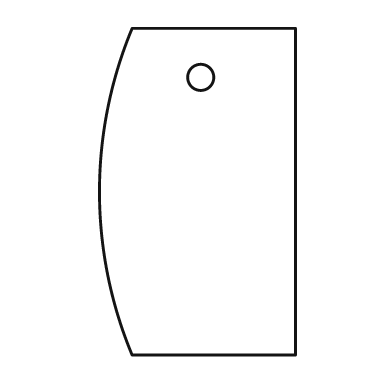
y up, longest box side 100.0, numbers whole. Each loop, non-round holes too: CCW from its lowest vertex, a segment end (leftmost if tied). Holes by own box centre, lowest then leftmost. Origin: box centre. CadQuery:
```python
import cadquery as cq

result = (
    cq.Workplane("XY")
    .moveTo(-20.0, -50.0)
    .lineTo(30.0, -50.0)
    .lineTo(30.0, 50.0)
    .lineTo(-20.0, 50.0)
    .threePointArc((-30.0, 0.0), (-20.0, -50.0))
    .close()
    .moveTo(1.0, 35.0)
    .circle(4.0)
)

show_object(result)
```